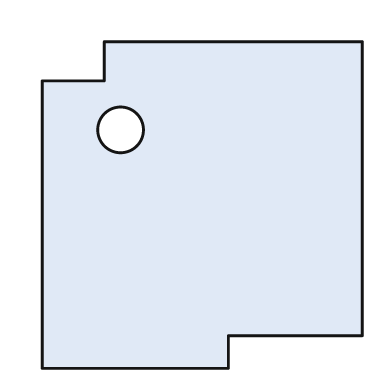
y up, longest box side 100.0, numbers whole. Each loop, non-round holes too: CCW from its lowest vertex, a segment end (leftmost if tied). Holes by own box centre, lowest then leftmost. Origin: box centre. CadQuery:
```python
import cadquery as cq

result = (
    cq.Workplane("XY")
    .moveTo(-49.0, -50.0)
    .lineTo(8.0, -50.0)
    .lineTo(8.0, -40.0)
    .lineTo(49.0, -40.0)
    .lineTo(49.0, 50.0)
    .lineTo(-30.0, 50.0)
    .lineTo(-30.0, 38.0)
    .lineTo(-49.0, 38.0)
    .close()
    .moveTo(-25.0, 23.0)
    .circle(7.0)
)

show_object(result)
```